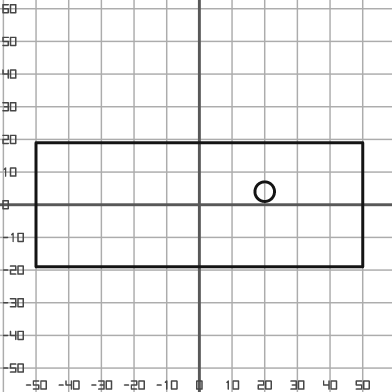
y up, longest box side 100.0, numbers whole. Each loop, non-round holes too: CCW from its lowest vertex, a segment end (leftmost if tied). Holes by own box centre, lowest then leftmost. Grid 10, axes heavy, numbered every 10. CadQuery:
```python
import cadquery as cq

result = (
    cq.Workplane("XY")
    .moveTo(-50.0, -19.0)
    .lineTo(50.0, -19.0)
    .lineTo(50.0, 19.0)
    .lineTo(-50.0, 19.0)
    .close()
    .moveTo(20.0, 4.0)
    .circle(3.0)
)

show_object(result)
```